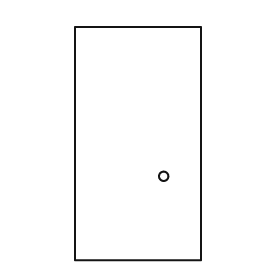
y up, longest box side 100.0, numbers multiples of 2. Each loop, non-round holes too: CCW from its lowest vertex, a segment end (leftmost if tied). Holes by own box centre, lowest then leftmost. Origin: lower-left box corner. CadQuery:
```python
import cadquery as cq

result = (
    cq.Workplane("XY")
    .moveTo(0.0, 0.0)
    .lineTo(54.0, 0.0)
    .lineTo(54.0, 100.0)
    .lineTo(0.0, 100.0)
    .close()
    .moveTo(38.0, 36.0)
    .circle(2.0)
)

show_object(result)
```